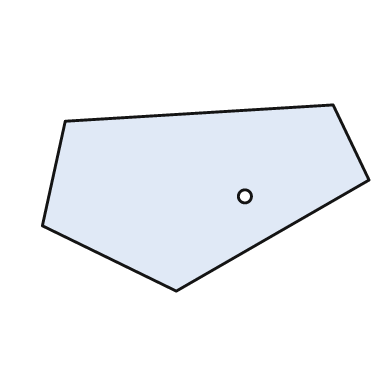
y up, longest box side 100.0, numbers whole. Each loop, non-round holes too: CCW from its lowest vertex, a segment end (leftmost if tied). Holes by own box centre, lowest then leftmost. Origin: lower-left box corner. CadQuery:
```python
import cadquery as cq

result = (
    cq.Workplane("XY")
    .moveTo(41.0, 0.0)
    .lineTo(100.0, 34.0)
    .lineTo(89.0, 57.0)
    .lineTo(7.0, 52.0)
    .lineTo(0.0, 20.0)
    .close()
    .moveTo(62.0, 29.0)
    .circle(2.0)
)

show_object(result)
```